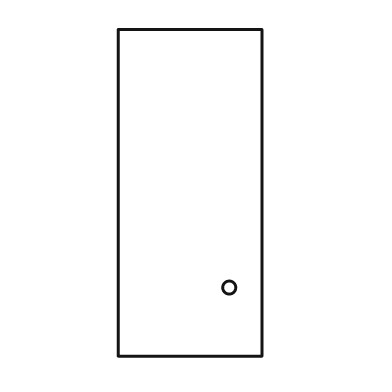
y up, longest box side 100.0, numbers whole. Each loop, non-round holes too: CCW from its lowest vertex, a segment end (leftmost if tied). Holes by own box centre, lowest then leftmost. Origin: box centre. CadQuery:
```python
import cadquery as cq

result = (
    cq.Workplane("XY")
    .moveTo(-22.0, -50.0)
    .lineTo(22.0, -50.0)
    .lineTo(22.0, 50.0)
    .lineTo(-22.0, 50.0)
    .close()
    .moveTo(12.0, -29.0)
    .circle(2.0)
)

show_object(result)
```